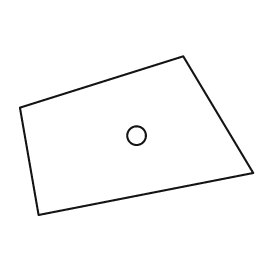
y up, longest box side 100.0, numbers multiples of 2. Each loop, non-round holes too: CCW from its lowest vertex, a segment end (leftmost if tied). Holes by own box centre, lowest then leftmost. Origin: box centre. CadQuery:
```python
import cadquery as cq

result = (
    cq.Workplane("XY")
    .moveTo(-42.0, -34.0)
    .lineTo(50.0, -16.0)
    .lineTo(20.0, 34.0)
    .lineTo(-50.0, 12.0)
    .close()
    .moveTo(0.0, 0.0)
    .circle(4.0)
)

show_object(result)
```